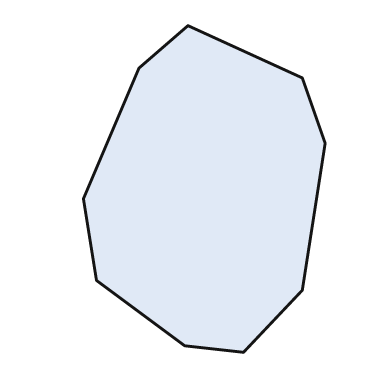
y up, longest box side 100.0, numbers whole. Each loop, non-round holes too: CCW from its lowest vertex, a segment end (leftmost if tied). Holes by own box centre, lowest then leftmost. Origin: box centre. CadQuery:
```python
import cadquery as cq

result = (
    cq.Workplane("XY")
    .moveTo(12.0, -50.0)
    .lineTo(30.0, -31.0)
    .lineTo(37.0, 14.0)
    .lineTo(30.0, 34.0)
    .lineTo(-5.0, 50.0)
    .lineTo(-20.0, 37.0)
    .lineTo(-37.0, -3.0)
    .lineTo(-33.0, -28.0)
    .lineTo(-6.0, -48.0)
    .close()
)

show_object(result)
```